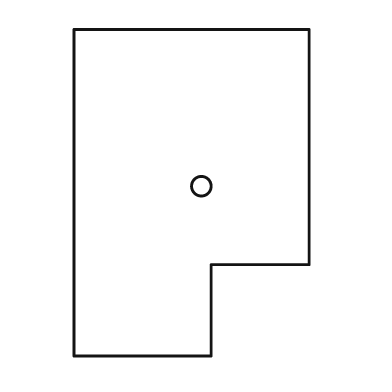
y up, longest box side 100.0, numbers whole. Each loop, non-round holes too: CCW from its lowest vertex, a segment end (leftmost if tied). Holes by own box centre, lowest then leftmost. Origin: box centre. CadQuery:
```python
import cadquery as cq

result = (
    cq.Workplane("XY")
    .moveTo(-36.0, -50.0)
    .lineTo(6.0, -50.0)
    .lineTo(6.0, -22.0)
    .lineTo(36.0, -22.0)
    .lineTo(36.0, 50.0)
    .lineTo(-36.0, 50.0)
    .close()
    .moveTo(3.0, 2.0)
    .circle(3.0)
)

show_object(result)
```